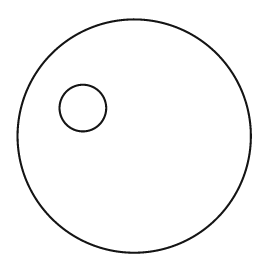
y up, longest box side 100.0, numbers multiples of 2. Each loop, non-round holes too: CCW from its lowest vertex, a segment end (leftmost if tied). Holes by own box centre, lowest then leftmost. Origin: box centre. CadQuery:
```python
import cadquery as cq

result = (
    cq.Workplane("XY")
    .moveTo(0.0, 0.0)
    .circle(50.0)
    .moveTo(-22.0, 12.0)
    .circle(10.0)
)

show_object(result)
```